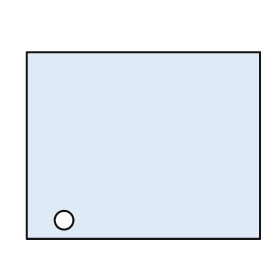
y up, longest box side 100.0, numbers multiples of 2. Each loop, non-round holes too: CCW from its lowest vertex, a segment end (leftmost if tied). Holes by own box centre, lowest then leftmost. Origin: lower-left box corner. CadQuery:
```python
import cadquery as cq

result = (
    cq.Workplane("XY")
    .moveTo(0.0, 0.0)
    .lineTo(100.0, 0.0)
    .lineTo(100.0, 80.0)
    .lineTo(0.0, 80.0)
    .close()
    .moveTo(16.0, 8.0)
    .circle(4.0)
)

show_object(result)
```